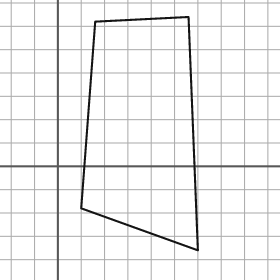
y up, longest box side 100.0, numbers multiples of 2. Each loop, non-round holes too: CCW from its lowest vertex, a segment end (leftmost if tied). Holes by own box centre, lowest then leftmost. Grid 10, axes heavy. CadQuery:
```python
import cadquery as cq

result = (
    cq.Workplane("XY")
    .moveTo(60.0, -36.0)
    .lineTo(56.0, 64.0)
    .lineTo(16.0, 62.0)
    .lineTo(10.0, -18.0)
    .close()
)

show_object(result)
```